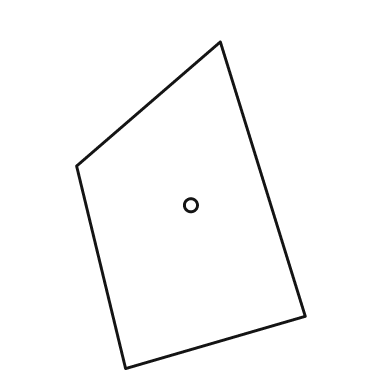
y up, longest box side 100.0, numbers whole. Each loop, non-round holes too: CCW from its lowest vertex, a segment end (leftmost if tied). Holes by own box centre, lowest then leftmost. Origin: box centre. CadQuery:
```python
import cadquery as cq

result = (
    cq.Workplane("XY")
    .moveTo(-20.0, -50.0)
    .lineTo(35.0, -34.0)
    .lineTo(9.0, 50.0)
    .lineTo(-35.0, 12.0)
    .close()
    .moveTo(0.0, 0.0)
    .circle(2.0)
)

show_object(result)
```